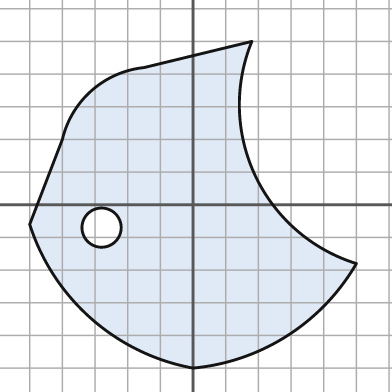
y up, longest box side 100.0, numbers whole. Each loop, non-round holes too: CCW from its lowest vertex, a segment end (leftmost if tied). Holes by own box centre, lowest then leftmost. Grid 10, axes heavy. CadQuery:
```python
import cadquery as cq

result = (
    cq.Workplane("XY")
    .moveTo(0.0, -50.0)
    .threePointArc((29.0, -40.0), (50.0, -18.0))
    .threePointArc((19.0, 9.0), (18.0, 50.0))
    .lineTo(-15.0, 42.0)
    .threePointArc((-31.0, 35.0), (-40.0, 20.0))
    .lineTo(-50.0, -6.0)
    .threePointArc((-31.0, -35.0), (0.0, -50.0))
    .close()
    .moveTo(-28.0, -7.0)
    .circle(6.0)
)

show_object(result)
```